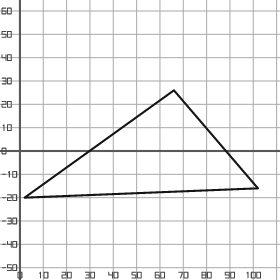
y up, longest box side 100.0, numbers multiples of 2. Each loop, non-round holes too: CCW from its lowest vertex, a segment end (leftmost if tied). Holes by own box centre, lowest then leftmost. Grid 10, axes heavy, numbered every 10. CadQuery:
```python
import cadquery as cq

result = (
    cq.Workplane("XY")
    .moveTo(2.0, -20.0)
    .lineTo(102.0, -16.0)
    .lineTo(66.0, 26.0)
    .close()
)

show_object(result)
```